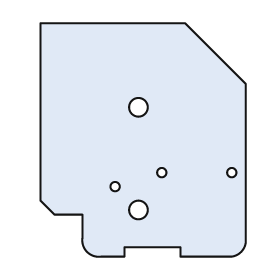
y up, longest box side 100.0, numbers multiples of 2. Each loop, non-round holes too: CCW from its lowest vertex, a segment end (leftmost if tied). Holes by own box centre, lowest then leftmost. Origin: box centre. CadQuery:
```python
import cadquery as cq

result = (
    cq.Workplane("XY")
    .moveTo(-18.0, -50.0)
    .lineTo(-8.0, -50.0)
    .lineTo(-8.0, -46.0)
    .lineTo(16.0, -46.0)
    .lineTo(16.0, -50.0)
    .lineTo(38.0, -50.0)
    .threePointArc((42.0, -48.0), (44.0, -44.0))
    .lineTo(44.0, 24.0)
    .lineTo(18.0, 50.0)
    .lineTo(-44.0, 50.0)
    .lineTo(-44.0, -26.0)
    .lineTo(-38.0, -32.0)
    .lineTo(-26.0, -32.0)
    .lineTo(-26.0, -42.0)
    .threePointArc((-24.0, -48.0), (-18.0, -50.0))
    .close()
    .moveTo(-2.0, -30.0)
    .circle(4.0)
    .moveTo(-12.0, -20.0)
    .circle(2.0)
    .moveTo(8.0, -14.0)
    .circle(2.0)
    .moveTo(38.0, -14.0)
    .circle(2.0)
    .moveTo(-2.0, 14.0)
    .circle(4.0)
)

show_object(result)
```